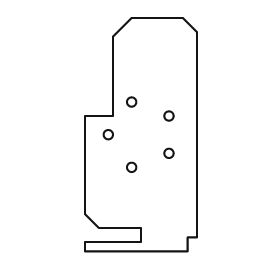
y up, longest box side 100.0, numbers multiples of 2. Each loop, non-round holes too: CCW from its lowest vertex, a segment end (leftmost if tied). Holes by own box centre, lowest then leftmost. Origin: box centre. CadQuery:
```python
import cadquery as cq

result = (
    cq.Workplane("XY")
    .moveTo(-24.0, -50.0)
    .lineTo(20.0, -50.0)
    .lineTo(20.0, -44.0)
    .lineTo(24.0, -44.0)
    .lineTo(24.0, 44.0)
    .lineTo(18.0, 50.0)
    .lineTo(-4.0, 50.0)
    .lineTo(-12.0, 42.0)
    .lineTo(-12.0, 8.0)
    .lineTo(-24.0, 8.0)
    .lineTo(-24.0, -34.0)
    .lineTo(-18.0, -40.0)
    .lineTo(0.0, -40.0)
    .lineTo(0.0, -46.0)
    .lineTo(-24.0, -46.0)
    .close()
    .moveTo(-4.0, -14.0)
    .circle(2.0)
    .moveTo(12.0, -8.0)
    .circle(2.0)
    .moveTo(-14.0, 0.0)
    .circle(2.0)
    .moveTo(12.0, 8.0)
    .circle(2.0)
    .moveTo(-4.0, 14.0)
    .circle(2.0)
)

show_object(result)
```